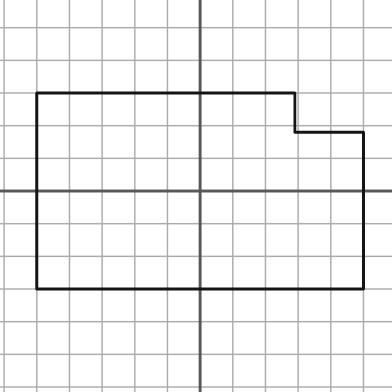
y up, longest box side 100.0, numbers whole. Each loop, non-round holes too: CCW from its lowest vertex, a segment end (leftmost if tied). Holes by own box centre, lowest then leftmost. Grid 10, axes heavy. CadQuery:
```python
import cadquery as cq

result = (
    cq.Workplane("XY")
    .moveTo(-50.0, -30.0)
    .lineTo(50.0, -30.0)
    .lineTo(50.0, 18.0)
    .lineTo(29.0, 18.0)
    .lineTo(29.0, 30.0)
    .lineTo(-50.0, 30.0)
    .close()
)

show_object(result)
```